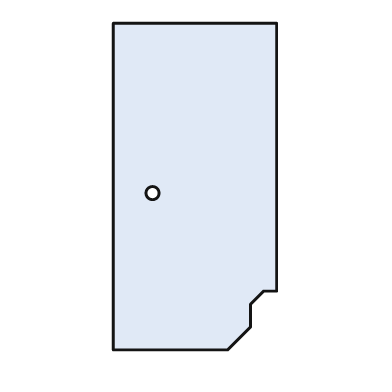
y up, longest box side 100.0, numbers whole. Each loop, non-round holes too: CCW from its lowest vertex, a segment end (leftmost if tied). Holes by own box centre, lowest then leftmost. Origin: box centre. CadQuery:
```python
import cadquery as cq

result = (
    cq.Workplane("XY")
    .moveTo(-25.0, -50.0)
    .lineTo(10.0, -50.0)
    .lineTo(17.0, -43.0)
    .lineTo(17.0, -36.0)
    .lineTo(21.0, -32.0)
    .lineTo(25.0, -32.0)
    .lineTo(25.0, 50.0)
    .lineTo(-25.0, 50.0)
    .close()
    .moveTo(-13.0, -2.0)
    .circle(2.0)
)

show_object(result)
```